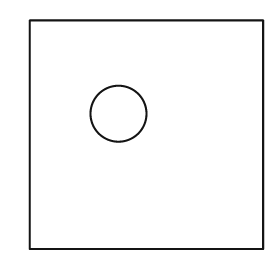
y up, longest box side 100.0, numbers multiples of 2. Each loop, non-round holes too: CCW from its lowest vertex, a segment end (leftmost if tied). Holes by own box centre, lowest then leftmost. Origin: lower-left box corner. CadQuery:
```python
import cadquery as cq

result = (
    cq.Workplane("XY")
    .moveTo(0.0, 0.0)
    .lineTo(100.0, 0.0)
    .lineTo(100.0, 98.0)
    .lineTo(0.0, 98.0)
    .close()
    .moveTo(38.0, 58.0)
    .circle(12.0)
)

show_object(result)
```